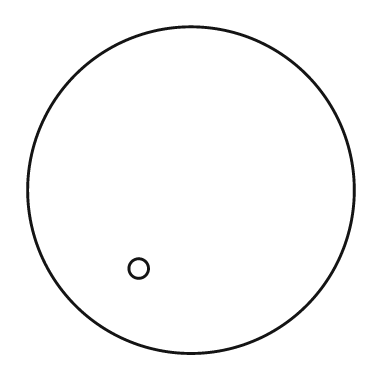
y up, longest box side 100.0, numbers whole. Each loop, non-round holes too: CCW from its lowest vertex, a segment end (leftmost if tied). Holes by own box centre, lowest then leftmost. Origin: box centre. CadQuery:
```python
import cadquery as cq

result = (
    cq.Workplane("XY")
    .moveTo(0.0, 0.0)
    .circle(50.0)
    .moveTo(-16.0, -24.0)
    .circle(3.0)
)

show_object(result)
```